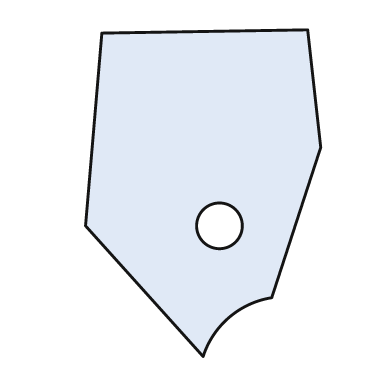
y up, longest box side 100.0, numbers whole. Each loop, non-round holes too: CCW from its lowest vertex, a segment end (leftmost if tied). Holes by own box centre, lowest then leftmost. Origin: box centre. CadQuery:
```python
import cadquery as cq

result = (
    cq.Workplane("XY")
    .moveTo(0.0, -50.0)
    .threePointArc((8.0, -38.0), (21.0, -32.0))
    .lineTo(36.0, 14.0)
    .lineTo(32.0, 50.0)
    .lineTo(-31.0, 49.0)
    .lineTo(-36.0, -10.0)
    .close()
    .moveTo(5.0, -10.0)
    .circle(7.0)
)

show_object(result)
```